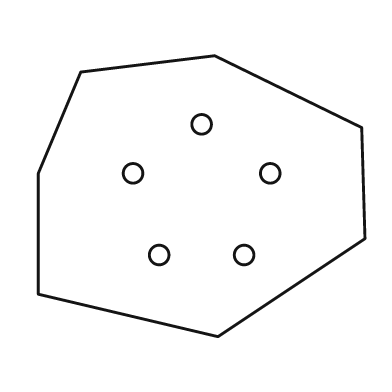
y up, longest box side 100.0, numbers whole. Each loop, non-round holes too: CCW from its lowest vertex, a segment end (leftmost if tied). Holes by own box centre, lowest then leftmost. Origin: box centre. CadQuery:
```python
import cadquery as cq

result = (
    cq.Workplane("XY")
    .moveTo(5.0, -43.0)
    .lineTo(50.0, -13.0)
    .lineTo(49.0, 21.0)
    .lineTo(4.0, 43.0)
    .lineTo(-37.0, 38.0)
    .lineTo(-50.0, 7.0)
    .lineTo(-50.0, -30.0)
    .close()
    .moveTo(-13.0, -18.0)
    .circle(3.0)
    .moveTo(13.0, -18.0)
    .circle(3.0)
    .moveTo(-21.0, 7.0)
    .circle(3.0)
    .moveTo(21.0, 7.0)
    .circle(3.0)
    .moveTo(0.0, 22.0)
    .circle(3.0)
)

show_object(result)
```